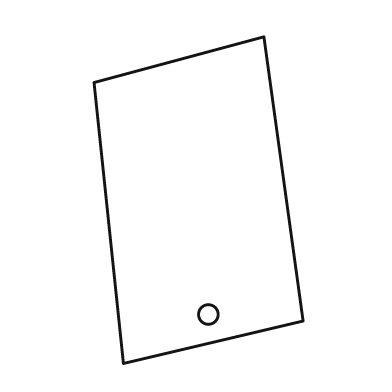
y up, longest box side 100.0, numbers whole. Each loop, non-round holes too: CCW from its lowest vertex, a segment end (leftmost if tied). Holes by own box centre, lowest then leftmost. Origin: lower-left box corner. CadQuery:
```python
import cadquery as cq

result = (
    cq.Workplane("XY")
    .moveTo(9.0, 0.0)
    .lineTo(64.0, 13.0)
    .lineTo(52.0, 100.0)
    .lineTo(0.0, 86.0)
    .close()
    .moveTo(35.0, 15.0)
    .circle(3.0)
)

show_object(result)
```